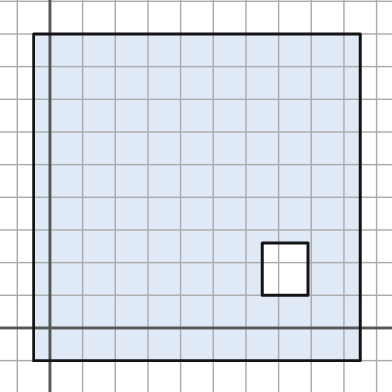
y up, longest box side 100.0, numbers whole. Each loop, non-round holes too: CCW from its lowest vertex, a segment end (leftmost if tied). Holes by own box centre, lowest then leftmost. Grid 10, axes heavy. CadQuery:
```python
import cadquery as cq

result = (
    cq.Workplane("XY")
    .moveTo(-5.0, -10.0)
    .lineTo(95.0, -10.0)
    .lineTo(95.0, 90.0)
    .lineTo(-5.0, 90.0)
    .close()
    .moveTo(65.0, 10.0)
    .lineTo(79.0, 10.0)
    .lineTo(79.0, 26.0)
    .lineTo(65.0, 26.0)
    .close()
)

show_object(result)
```